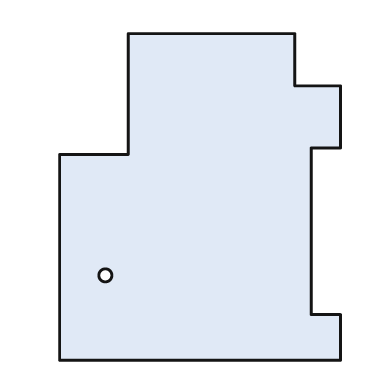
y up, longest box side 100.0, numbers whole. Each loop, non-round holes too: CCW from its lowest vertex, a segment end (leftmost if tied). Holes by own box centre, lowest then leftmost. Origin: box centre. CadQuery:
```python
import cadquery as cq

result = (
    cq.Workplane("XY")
    .moveTo(-43.0, -50.0)
    .lineTo(43.0, -50.0)
    .lineTo(43.0, -36.0)
    .lineTo(34.0, -36.0)
    .lineTo(34.0, 15.0)
    .lineTo(43.0, 15.0)
    .lineTo(43.0, 34.0)
    .lineTo(29.0, 34.0)
    .lineTo(29.0, 50.0)
    .lineTo(-22.0, 50.0)
    .lineTo(-22.0, 13.0)
    .lineTo(-43.0, 13.0)
    .close()
    .moveTo(-29.0, -24.0)
    .circle(2.0)
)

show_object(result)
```